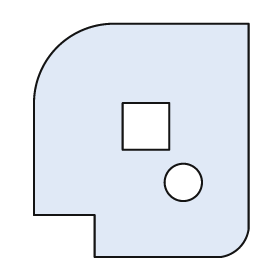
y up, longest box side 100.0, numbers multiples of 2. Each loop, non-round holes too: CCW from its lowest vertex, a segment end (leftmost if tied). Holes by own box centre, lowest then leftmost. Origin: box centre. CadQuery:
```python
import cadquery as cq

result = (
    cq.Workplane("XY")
    .moveTo(-20.0, -50.0)
    .lineTo(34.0, -50.0)
    .threePointArc((42.0, -46.0), (46.0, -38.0))
    .lineTo(46.0, 50.0)
    .lineTo(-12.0, 50.0)
    .threePointArc((-36.0, 40.0), (-46.0, 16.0))
    .lineTo(-46.0, -32.0)
    .lineTo(-20.0, -32.0)
    .close()
    .moveTo(18.0, -18.0)
    .circle(8.0)
    .moveTo(-8.0, -4.0)
    .lineTo(12.0, -4.0)
    .lineTo(12.0, 16.0)
    .lineTo(-8.0, 16.0)
    .close()
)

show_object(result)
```